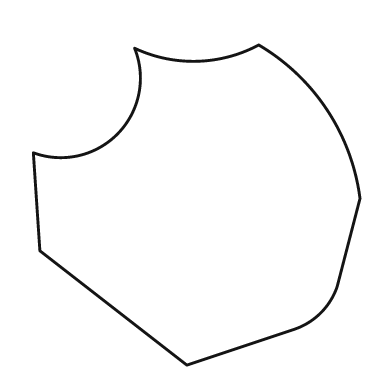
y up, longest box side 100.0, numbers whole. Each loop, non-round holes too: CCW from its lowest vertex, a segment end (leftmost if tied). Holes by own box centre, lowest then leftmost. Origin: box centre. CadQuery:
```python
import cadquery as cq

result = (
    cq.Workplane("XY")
    .moveTo(-3.0, -49.0)
    .lineTo(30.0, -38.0)
    .threePointArc((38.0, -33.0), (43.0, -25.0))
    .lineTo(50.0, 2.0)
    .threePointArc((40.0, 29.0), (19.0, 49.0))
    .threePointArc((0.0, 44.0), (-19.0, 48.0))
    .threePointArc((-24.0, 22.0), (-50.0, 16.0))
    .lineTo(-48.0, -14.0)
    .close()
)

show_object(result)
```